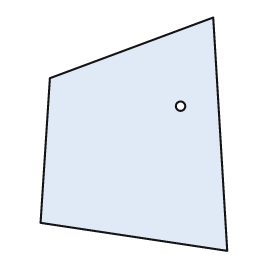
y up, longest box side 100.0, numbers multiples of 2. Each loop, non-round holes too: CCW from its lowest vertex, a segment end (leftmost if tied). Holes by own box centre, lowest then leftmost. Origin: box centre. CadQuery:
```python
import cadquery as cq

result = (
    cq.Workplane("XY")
    .moveTo(40.0, -50.0)
    .lineTo(34.0, 50.0)
    .lineTo(-36.0, 24.0)
    .lineTo(-40.0, -38.0)
    .close()
    .moveTo(20.0, 12.0)
    .circle(2.0)
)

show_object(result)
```